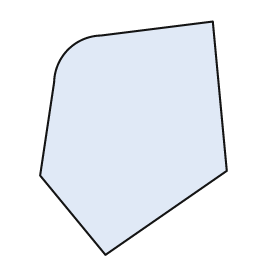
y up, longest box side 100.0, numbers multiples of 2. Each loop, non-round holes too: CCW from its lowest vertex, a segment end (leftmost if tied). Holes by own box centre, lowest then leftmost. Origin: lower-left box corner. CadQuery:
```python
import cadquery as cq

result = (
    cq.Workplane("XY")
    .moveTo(28.0, 0.0)
    .lineTo(80.0, 36.0)
    .lineTo(74.0, 100.0)
    .lineTo(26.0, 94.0)
    .threePointArc((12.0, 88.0), (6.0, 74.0))
    .lineTo(0.0, 34.0)
    .close()
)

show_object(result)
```